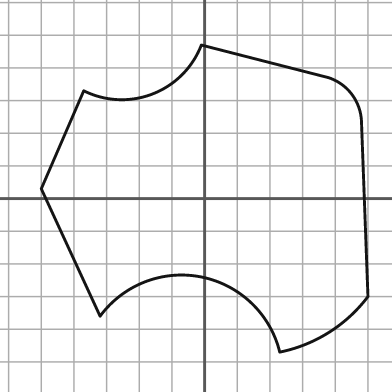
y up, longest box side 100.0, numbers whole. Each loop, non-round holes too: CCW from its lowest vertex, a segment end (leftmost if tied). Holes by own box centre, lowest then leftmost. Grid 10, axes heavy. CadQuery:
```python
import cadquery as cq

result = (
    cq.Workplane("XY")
    .moveTo(23.0, -47.0)
    .threePointArc((38.0, -41.0), (50.0, -30.0))
    .lineTo(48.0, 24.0)
    .threePointArc((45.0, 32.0), (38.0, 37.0))
    .lineTo(-1.0, 47.0)
    .threePointArc((-16.0, 32.0), (-37.0, 33.0))
    .lineTo(-50.0, 3.0)
    .lineTo(-32.0, -36.0)
    .threePointArc((-1.0, -24.0), (23.0, -47.0))
    .close()
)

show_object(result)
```